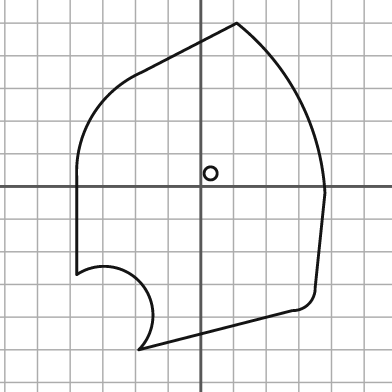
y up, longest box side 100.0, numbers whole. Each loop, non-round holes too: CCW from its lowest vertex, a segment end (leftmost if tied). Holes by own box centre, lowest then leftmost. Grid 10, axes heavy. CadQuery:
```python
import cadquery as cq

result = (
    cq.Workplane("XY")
    .moveTo(-19.0, -50.0)
    .lineTo(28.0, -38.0)
    .threePointArc((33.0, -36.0), (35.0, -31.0))
    .lineTo(38.0, -2.0)
    .threePointArc((30.0, 27.0), (11.0, 50.0))
    .lineTo(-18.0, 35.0)
    .threePointArc((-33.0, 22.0), (-38.0, 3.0))
    .lineTo(-38.0, -27.0)
    .threePointArc((-18.0, -30.0), (-19.0, -50.0))
    .close()
    .moveTo(3.0, 4.0)
    .circle(2.0)
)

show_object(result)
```